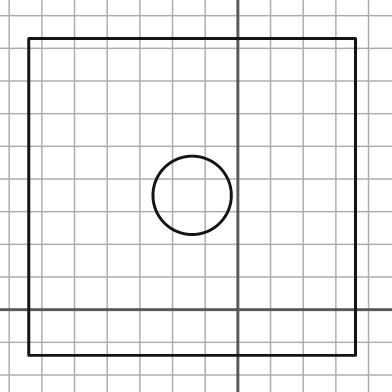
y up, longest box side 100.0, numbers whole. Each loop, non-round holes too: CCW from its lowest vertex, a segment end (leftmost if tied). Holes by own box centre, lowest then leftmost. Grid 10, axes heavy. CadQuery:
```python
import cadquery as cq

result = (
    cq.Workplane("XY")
    .moveTo(-64.0, -14.0)
    .lineTo(36.0, -14.0)
    .lineTo(36.0, 83.0)
    .lineTo(-64.0, 83.0)
    .close()
    .moveTo(-14.0, 35.0)
    .circle(12.0)
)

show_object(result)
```